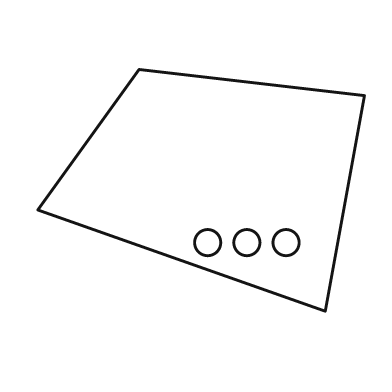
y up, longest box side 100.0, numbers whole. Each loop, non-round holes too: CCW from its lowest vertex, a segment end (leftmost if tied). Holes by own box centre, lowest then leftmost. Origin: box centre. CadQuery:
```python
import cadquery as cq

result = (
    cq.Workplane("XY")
    .moveTo(38.0, -37.0)
    .lineTo(50.0, 29.0)
    .lineTo(-19.0, 37.0)
    .lineTo(-50.0, -6.0)
    .close()
    .moveTo(2.0, -16.0)
    .circle(4.0)
    .moveTo(14.0, -16.0)
    .circle(4.0)
    .moveTo(26.0, -16.0)
    .circle(4.0)
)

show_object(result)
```